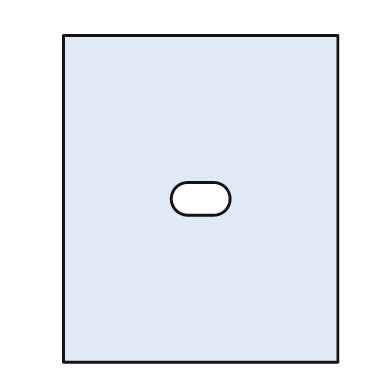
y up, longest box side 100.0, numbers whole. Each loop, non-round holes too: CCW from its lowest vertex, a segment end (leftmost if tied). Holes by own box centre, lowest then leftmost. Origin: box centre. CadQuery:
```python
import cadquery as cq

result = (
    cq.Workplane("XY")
    .moveTo(-42.0, -50.0)
    .lineTo(42.0, -50.0)
    .lineTo(42.0, 50.0)
    .lineTo(-42.0, 50.0)
    .close()
    .moveTo(-4.0, -5.0)
    .lineTo(4.0, -5.0)
    .threePointArc((9.0, 0.0), (4.0, 5.0))
    .lineTo(-4.0, 5.0)
    .threePointArc((-9.0, 0.0), (-4.0, -5.0))
    .close()
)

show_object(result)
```